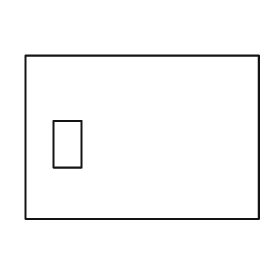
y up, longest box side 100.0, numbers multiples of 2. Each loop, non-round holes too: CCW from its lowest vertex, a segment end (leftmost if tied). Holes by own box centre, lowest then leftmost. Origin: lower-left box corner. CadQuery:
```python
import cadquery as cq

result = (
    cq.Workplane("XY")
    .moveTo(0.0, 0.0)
    .lineTo(100.0, 0.0)
    .lineTo(100.0, 70.0)
    .lineTo(0.0, 70.0)
    .close()
    .moveTo(12.0, 22.0)
    .lineTo(24.0, 22.0)
    .lineTo(24.0, 42.0)
    .lineTo(12.0, 42.0)
    .close()
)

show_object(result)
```